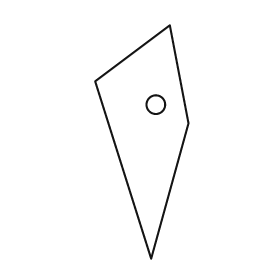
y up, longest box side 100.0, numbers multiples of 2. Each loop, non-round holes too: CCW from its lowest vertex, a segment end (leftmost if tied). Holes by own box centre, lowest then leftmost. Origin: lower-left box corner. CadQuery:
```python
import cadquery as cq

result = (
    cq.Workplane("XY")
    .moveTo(24.0, 0.0)
    .lineTo(40.0, 58.0)
    .lineTo(32.0, 100.0)
    .lineTo(0.0, 76.0)
    .close()
    .moveTo(26.0, 66.0)
    .circle(4.0)
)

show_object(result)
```